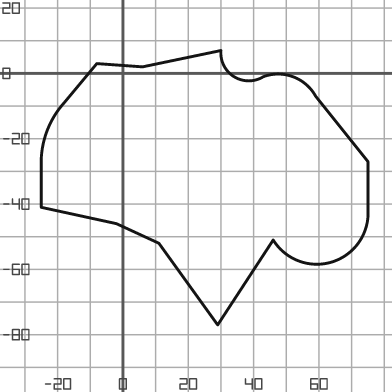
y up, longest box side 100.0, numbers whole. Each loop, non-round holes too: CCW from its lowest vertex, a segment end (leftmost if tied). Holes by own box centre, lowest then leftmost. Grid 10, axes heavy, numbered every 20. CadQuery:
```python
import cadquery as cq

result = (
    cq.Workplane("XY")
    .moveTo(29.0, -77.0)
    .lineTo(46.0, -51.0)
    .threePointArc((63.0, -58.0), (75.0, -44.0))
    .lineTo(75.0, -27.0)
    .lineTo(59.0, -7.0)
    .threePointArc((52.0, -1.0), (43.0, -1.0))
    .threePointArc((34.0, -1.0), (30.0, 7.0))
    .lineTo(6.0, 2.0)
    .lineTo(-8.0, 3.0)
    .lineTo(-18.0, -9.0)
    .threePointArc((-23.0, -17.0), (-25.0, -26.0))
    .lineTo(-25.0, -41.0)
    .lineTo(-2.0, -46.0)
    .lineTo(11.0, -52.0)
    .close()
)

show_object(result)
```